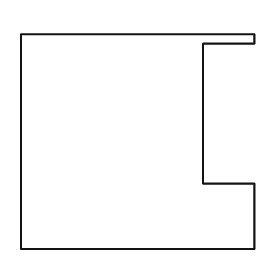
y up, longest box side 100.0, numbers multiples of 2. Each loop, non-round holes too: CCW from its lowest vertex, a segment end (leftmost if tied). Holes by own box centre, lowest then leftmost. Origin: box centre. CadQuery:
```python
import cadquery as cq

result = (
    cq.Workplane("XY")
    .moveTo(-50.0, -46.0)
    .lineTo(50.0, -46.0)
    .lineTo(50.0, -18.0)
    .lineTo(28.0, -18.0)
    .lineTo(28.0, 42.0)
    .lineTo(50.0, 42.0)
    .lineTo(50.0, 46.0)
    .lineTo(-50.0, 46.0)
    .close()
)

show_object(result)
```